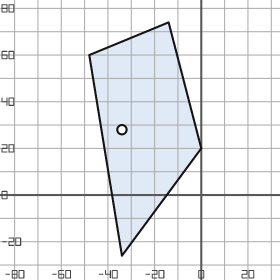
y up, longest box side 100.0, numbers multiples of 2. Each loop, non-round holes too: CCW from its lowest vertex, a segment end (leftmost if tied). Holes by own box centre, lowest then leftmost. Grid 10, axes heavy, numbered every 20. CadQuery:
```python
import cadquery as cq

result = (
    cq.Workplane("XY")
    .moveTo(-34.0, -26.0)
    .lineTo(0.0, 20.0)
    .lineTo(-14.0, 74.0)
    .lineTo(-48.0, 60.0)
    .close()
    .moveTo(-34.0, 28.0)
    .circle(2.0)
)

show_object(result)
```